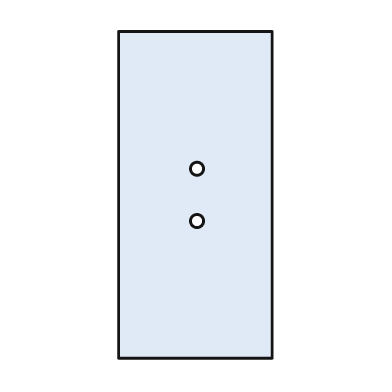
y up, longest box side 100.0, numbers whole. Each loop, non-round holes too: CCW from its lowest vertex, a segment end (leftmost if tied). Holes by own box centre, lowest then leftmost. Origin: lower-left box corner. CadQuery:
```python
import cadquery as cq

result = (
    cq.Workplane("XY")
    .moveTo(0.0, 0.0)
    .lineTo(47.0, 0.0)
    .lineTo(47.0, 100.0)
    .lineTo(0.0, 100.0)
    .close()
    .moveTo(24.0, 42.0)
    .circle(2.0)
    .moveTo(24.0, 58.0)
    .circle(2.0)
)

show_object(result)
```